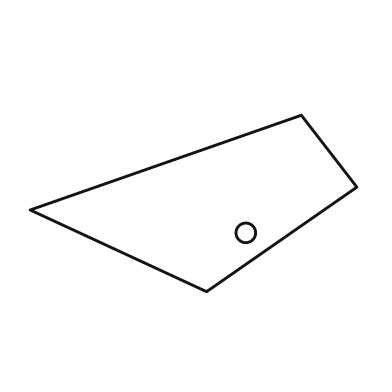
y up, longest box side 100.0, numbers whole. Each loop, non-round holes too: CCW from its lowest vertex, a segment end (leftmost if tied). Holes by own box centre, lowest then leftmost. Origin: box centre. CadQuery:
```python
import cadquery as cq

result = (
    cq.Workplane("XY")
    .moveTo(4.0, -27.0)
    .lineTo(50.0, 5.0)
    .lineTo(33.0, 27.0)
    .lineTo(-50.0, -2.0)
    .close()
    .moveTo(16.0, -9.0)
    .circle(3.0)
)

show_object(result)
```